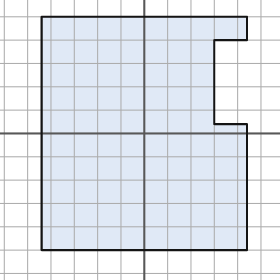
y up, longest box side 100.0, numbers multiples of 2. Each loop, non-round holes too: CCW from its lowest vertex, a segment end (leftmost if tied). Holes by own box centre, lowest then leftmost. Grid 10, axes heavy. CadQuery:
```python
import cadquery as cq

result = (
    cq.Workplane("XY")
    .moveTo(-44.0, -50.0)
    .lineTo(44.0, -50.0)
    .lineTo(44.0, 4.0)
    .lineTo(30.0, 4.0)
    .lineTo(30.0, 40.0)
    .lineTo(44.0, 40.0)
    .lineTo(44.0, 50.0)
    .lineTo(-44.0, 50.0)
    .close()
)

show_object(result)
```